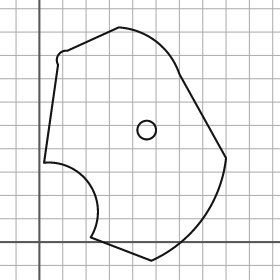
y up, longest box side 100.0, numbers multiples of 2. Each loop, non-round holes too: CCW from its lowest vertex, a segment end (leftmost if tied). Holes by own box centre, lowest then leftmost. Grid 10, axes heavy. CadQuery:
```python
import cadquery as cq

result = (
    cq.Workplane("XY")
    .moveTo(48.0, -8.0)
    .threePointArc((70.0, 10.0), (80.0, 36.0))
    .lineTo(60.0, 72.0)
    .threePointArc((50.0, 86.0), (34.0, 92.0))
    .lineTo(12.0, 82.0)
    .threePointArc((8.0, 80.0), (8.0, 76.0))
    .lineTo(2.0, 34.0)
    .threePointArc((22.0, 24.0), (22.0, 2.0))
    .close()
    .moveTo(46.0, 48.0)
    .circle(4.0)
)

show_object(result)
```